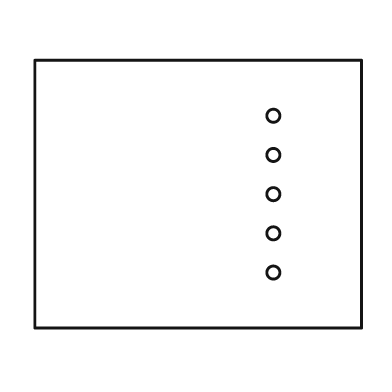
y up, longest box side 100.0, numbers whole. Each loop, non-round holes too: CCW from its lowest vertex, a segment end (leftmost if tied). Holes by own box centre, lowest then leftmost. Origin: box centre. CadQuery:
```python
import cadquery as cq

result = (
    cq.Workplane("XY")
    .moveTo(-50.0, -41.0)
    .lineTo(50.0, -41.0)
    .lineTo(50.0, 41.0)
    .lineTo(-50.0, 41.0)
    .close()
    .moveTo(23.0, -24.0)
    .circle(2.0)
    .moveTo(23.0, -12.0)
    .circle(2.0)
    .moveTo(23.0, 0.0)
    .circle(2.0)
    .moveTo(23.0, 12.0)
    .circle(2.0)
    .moveTo(23.0, 24.0)
    .circle(2.0)
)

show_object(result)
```